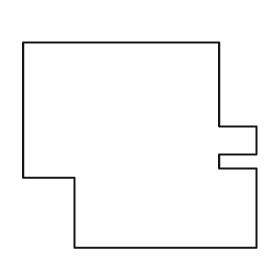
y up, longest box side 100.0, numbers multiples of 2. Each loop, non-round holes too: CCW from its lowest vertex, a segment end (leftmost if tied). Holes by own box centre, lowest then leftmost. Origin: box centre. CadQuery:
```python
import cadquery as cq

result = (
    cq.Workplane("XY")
    .moveTo(-28.0, -44.0)
    .lineTo(50.0, -44.0)
    .lineTo(50.0, -10.0)
    .lineTo(34.0, -10.0)
    .lineTo(34.0, -4.0)
    .lineTo(50.0, -4.0)
    .lineTo(50.0, 8.0)
    .lineTo(34.0, 8.0)
    .lineTo(34.0, 44.0)
    .lineTo(-50.0, 44.0)
    .lineTo(-50.0, -14.0)
    .lineTo(-28.0, -14.0)
    .close()
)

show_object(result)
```